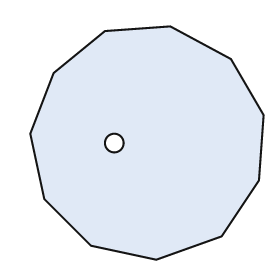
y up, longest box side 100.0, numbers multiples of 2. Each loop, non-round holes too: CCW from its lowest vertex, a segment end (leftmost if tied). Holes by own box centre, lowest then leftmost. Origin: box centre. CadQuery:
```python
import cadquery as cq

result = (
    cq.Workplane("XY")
    .moveTo(4.0, -50.0)
    .lineTo(32.0, -40.0)
    .lineTo(48.0, -16.0)
    .lineTo(50.0, 12.0)
    .lineTo(36.0, 36.0)
    .lineTo(10.0, 50.0)
    .lineTo(-18.0, 48.0)
    .lineTo(-40.0, 30.0)
    .lineTo(-50.0, 4.0)
    .lineTo(-44.0, -24.0)
    .lineTo(-24.0, -44.0)
    .close()
    .moveTo(-14.0, 0.0)
    .circle(4.0)
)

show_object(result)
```